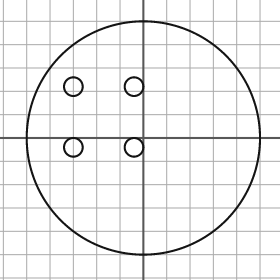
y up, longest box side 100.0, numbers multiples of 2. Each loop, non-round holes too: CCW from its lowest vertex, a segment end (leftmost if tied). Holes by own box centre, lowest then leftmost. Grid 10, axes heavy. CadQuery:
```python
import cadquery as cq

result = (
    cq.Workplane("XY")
    .moveTo(0.0, 0.0)
    .circle(50.0)
    .moveTo(-30.0, -4.0)
    .circle(4.0)
    .moveTo(-4.0, -4.0)
    .circle(4.0)
    .moveTo(-30.0, 22.0)
    .circle(4.0)
    .moveTo(-4.0, 22.0)
    .circle(4.0)
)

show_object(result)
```